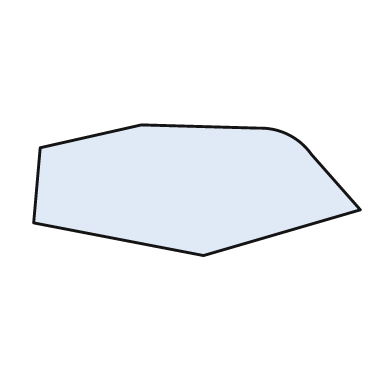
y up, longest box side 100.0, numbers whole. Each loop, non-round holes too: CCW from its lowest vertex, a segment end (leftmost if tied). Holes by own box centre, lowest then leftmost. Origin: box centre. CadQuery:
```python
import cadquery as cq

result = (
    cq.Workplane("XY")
    .moveTo(2.0, -20.0)
    .lineTo(50.0, -6.0)
    .lineTo(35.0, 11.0)
    .threePointArc((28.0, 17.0), (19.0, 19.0))
    .lineTo(-17.0, 20.0)
    .lineTo(-48.0, 13.0)
    .lineTo(-50.0, -10.0)
    .close()
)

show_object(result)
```